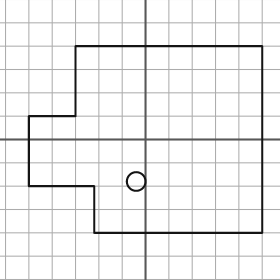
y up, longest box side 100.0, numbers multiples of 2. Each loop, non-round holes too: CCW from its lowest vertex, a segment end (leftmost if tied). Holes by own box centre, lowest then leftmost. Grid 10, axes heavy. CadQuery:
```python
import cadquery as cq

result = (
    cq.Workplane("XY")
    .moveTo(-22.0, -40.0)
    .lineTo(50.0, -40.0)
    .lineTo(50.0, 40.0)
    .lineTo(-30.0, 40.0)
    .lineTo(-30.0, 10.0)
    .lineTo(-50.0, 10.0)
    .lineTo(-50.0, -20.0)
    .lineTo(-22.0, -20.0)
    .close()
    .moveTo(-4.0, -18.0)
    .circle(4.0)
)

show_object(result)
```